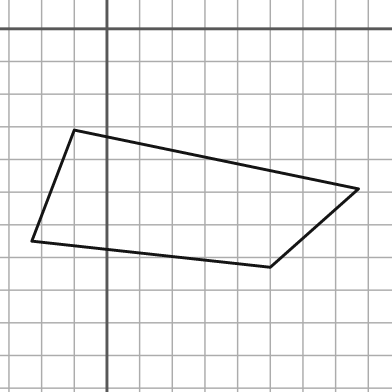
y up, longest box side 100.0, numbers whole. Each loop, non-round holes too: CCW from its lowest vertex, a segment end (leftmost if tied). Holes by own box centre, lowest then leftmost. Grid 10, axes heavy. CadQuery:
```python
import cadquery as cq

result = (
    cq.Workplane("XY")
    .moveTo(50.0, -73.0)
    .lineTo(77.0, -49.0)
    .lineTo(-10.0, -31.0)
    .lineTo(-23.0, -65.0)
    .close()
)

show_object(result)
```